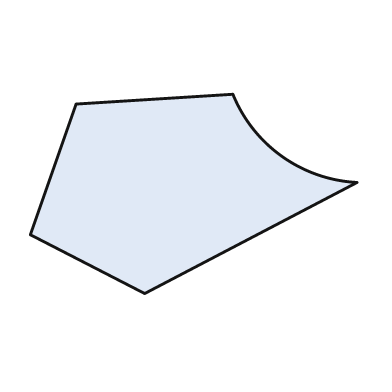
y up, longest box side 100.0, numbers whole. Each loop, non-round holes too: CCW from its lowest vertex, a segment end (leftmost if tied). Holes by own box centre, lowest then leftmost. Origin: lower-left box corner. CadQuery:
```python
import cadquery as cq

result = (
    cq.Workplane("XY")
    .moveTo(35.0, 0.0)
    .lineTo(100.0, 34.0)
    .threePointArc((77.0, 42.0), (62.0, 61.0))
    .lineTo(14.0, 58.0)
    .lineTo(0.0, 18.0)
    .close()
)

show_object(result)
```